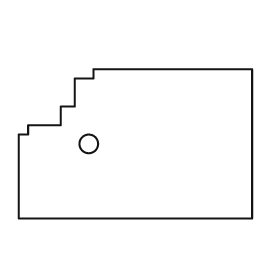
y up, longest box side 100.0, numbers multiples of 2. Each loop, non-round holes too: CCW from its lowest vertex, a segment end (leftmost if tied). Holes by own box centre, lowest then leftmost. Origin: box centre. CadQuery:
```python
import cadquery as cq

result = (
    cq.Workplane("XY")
    .moveTo(-50.0, -32.0)
    .lineTo(50.0, -32.0)
    .lineTo(50.0, 32.0)
    .lineTo(-18.0, 32.0)
    .lineTo(-18.0, 28.0)
    .lineTo(-26.0, 28.0)
    .lineTo(-26.0, 16.0)
    .lineTo(-32.0, 16.0)
    .lineTo(-32.0, 8.0)
    .lineTo(-46.0, 8.0)
    .lineTo(-46.0, 4.0)
    .lineTo(-50.0, 4.0)
    .close()
    .moveTo(-20.0, 0.0)
    .circle(4.0)
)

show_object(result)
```